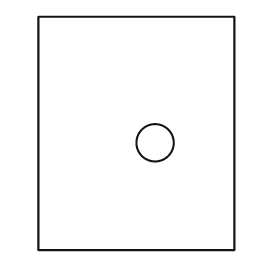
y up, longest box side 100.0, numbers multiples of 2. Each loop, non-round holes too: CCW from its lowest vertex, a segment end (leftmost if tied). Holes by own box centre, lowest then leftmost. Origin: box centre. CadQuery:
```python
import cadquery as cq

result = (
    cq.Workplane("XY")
    .moveTo(-42.0, -50.0)
    .lineTo(42.0, -50.0)
    .lineTo(42.0, 50.0)
    .lineTo(-42.0, 50.0)
    .close()
    .moveTo(8.0, -4.0)
    .circle(8.0)
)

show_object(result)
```